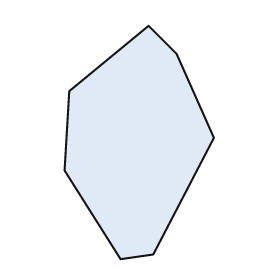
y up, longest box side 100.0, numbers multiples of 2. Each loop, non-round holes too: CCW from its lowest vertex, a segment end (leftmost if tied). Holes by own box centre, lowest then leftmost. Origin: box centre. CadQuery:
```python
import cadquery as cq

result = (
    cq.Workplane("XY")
    .moveTo(-8.0, -50.0)
    .lineTo(6.0, -48.0)
    .lineTo(32.0, 2.0)
    .lineTo(16.0, 38.0)
    .lineTo(4.0, 50.0)
    .lineTo(-30.0, 22.0)
    .lineTo(-32.0, -12.0)
    .close()
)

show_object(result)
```